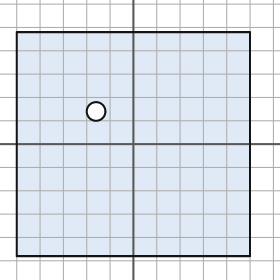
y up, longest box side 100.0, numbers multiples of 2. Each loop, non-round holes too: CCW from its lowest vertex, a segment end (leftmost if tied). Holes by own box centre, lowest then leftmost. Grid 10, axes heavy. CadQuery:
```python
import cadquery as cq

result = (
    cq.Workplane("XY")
    .moveTo(-50.0, -48.0)
    .lineTo(50.0, -48.0)
    .lineTo(50.0, 48.0)
    .lineTo(-50.0, 48.0)
    .close()
    .moveTo(-16.0, 14.0)
    .circle(4.0)
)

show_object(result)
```